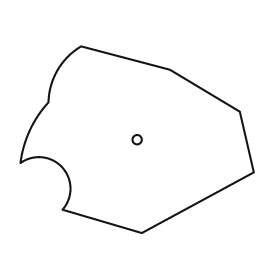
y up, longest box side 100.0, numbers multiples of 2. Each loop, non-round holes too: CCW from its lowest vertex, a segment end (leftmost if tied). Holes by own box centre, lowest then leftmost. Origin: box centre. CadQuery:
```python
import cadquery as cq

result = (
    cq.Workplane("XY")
    .moveTo(2.0, -40.0)
    .lineTo(50.0, -14.0)
    .lineTo(44.0, 12.0)
    .lineTo(14.0, 30.0)
    .lineTo(-24.0, 40.0)
    .threePointArc((-34.0, 30.0), (-38.0, 16.0))
    .threePointArc((-46.0, 4.0), (-50.0, -10.0))
    .threePointArc((-32.0, -12.0), (-32.0, -30.0))
    .close()
    .moveTo(0.0, 0.0)
    .circle(2.0)
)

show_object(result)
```